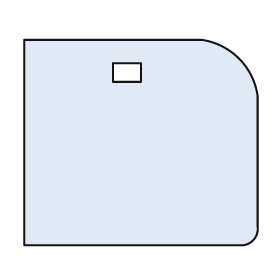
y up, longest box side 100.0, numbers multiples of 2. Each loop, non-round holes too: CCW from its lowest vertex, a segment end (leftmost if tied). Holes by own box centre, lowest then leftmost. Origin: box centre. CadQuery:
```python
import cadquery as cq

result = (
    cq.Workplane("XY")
    .moveTo(-50.0, -44.0)
    .lineTo(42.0, -44.0)
    .threePointArc((48.0, -42.0), (50.0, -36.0))
    .lineTo(50.0, 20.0)
    .threePointArc((42.0, 36.0), (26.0, 44.0))
    .lineTo(-50.0, 44.0)
    .close()
    .moveTo(-12.0, 26.0)
    .lineTo(0.0, 26.0)
    .lineTo(0.0, 34.0)
    .lineTo(-12.0, 34.0)
    .close()
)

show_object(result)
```